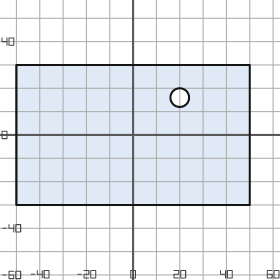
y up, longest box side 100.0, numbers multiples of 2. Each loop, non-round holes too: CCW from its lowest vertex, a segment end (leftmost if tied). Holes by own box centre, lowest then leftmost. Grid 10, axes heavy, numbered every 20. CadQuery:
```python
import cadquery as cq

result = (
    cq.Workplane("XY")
    .moveTo(-50.0, -30.0)
    .lineTo(50.0, -30.0)
    .lineTo(50.0, 30.0)
    .lineTo(-50.0, 30.0)
    .close()
    .moveTo(20.0, 16.0)
    .circle(4.0)
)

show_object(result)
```